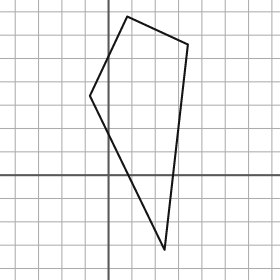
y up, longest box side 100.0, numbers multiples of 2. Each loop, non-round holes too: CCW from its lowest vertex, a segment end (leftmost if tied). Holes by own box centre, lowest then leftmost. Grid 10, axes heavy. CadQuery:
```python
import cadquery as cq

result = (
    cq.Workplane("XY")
    .moveTo(24.0, -32.0)
    .lineTo(34.0, 56.0)
    .lineTo(8.0, 68.0)
    .lineTo(-8.0, 34.0)
    .close()
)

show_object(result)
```